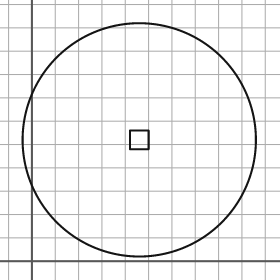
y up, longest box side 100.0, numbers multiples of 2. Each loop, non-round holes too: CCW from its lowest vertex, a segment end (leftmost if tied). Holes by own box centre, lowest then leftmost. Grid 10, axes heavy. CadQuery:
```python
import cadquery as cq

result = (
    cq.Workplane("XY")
    .moveTo(46.0, 52.0)
    .circle(50.0)
    .moveTo(42.0, 48.0)
    .lineTo(50.0, 48.0)
    .lineTo(50.0, 56.0)
    .lineTo(42.0, 56.0)
    .close()
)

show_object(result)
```